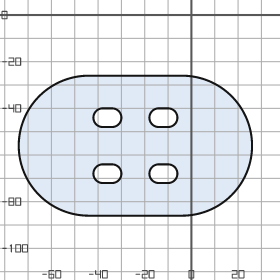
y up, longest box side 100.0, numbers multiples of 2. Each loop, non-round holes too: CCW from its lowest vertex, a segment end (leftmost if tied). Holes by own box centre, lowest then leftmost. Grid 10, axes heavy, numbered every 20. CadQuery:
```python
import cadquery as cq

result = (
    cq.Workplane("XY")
    .moveTo(-44.0, -86.0)
    .lineTo(-4.0, -86.0)
    .threePointArc((26.0, -56.0), (-4.0, -26.0))
    .lineTo(-44.0, -26.0)
    .threePointArc((-74.0, -56.0), (-44.0, -86.0))
    .close()
    .moveTo(-38.0, -72.0)
    .lineTo(-34.0, -72.0)
    .threePointArc((-30.0, -68.0), (-34.0, -64.0))
    .lineTo(-38.0, -64.0)
    .threePointArc((-42.0, -68.0), (-38.0, -72.0))
    .close()
    .moveTo(-14.0, -72.0)
    .lineTo(-10.0, -72.0)
    .threePointArc((-6.0, -68.0), (-10.0, -64.0))
    .lineTo(-14.0, -64.0)
    .threePointArc((-18.0, -68.0), (-14.0, -72.0))
    .close()
    .moveTo(-38.0, -48.0)
    .lineTo(-34.0, -48.0)
    .threePointArc((-30.0, -44.0), (-34.0, -40.0))
    .lineTo(-38.0, -40.0)
    .threePointArc((-42.0, -44.0), (-38.0, -48.0))
    .close()
    .moveTo(-14.0, -48.0)
    .lineTo(-10.0, -48.0)
    .threePointArc((-6.0, -44.0), (-10.0, -40.0))
    .lineTo(-14.0, -40.0)
    .threePointArc((-18.0, -44.0), (-14.0, -48.0))
    .close()
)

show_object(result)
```